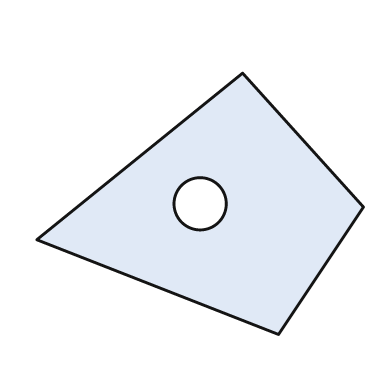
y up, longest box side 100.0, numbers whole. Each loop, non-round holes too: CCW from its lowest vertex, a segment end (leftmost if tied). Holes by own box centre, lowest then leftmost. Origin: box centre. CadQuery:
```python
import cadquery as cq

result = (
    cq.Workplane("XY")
    .moveTo(24.0, -40.0)
    .lineTo(50.0, -1.0)
    .lineTo(13.0, 40.0)
    .lineTo(-50.0, -11.0)
    .close()
    .moveTo(0.0, 0.0)
    .circle(8.0)
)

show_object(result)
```